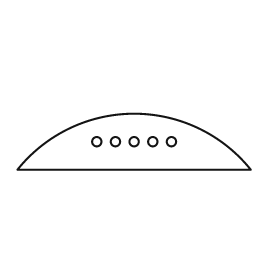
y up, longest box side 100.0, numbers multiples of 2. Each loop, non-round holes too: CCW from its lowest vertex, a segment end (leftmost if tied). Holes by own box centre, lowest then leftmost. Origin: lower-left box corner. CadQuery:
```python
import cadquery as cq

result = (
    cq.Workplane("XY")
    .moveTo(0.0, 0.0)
    .lineTo(100.0, 0.0)
    .threePointArc((50.0, 24.0), (0.0, 0.0))
    .close()
    .moveTo(34.0, 12.0)
    .circle(2.0)
    .moveTo(42.0, 12.0)
    .circle(2.0)
    .moveTo(50.0, 12.0)
    .circle(2.0)
    .moveTo(58.0, 12.0)
    .circle(2.0)
    .moveTo(66.0, 12.0)
    .circle(2.0)
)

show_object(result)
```